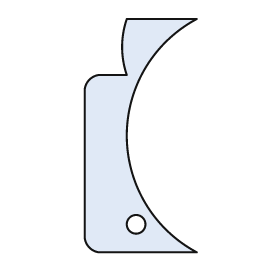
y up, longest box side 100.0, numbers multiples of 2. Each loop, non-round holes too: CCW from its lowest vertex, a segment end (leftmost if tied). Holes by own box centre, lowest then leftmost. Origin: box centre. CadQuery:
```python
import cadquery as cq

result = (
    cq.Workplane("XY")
    .moveTo(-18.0, -50.0)
    .lineTo(24.0, -50.0)
    .threePointArc((-6.0, 0.0), (24.0, 50.0))
    .lineTo(-6.0, 50.0)
    .threePointArc((-8.0, 38.0), (-6.0, 26.0))
    .lineTo(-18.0, 26.0)
    .threePointArc((-22.0, 24.0), (-24.0, 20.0))
    .lineTo(-24.0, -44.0)
    .threePointArc((-22.0, -48.0), (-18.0, -50.0))
    .close()
    .moveTo(-2.0, -38.0)
    .circle(4.0)
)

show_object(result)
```